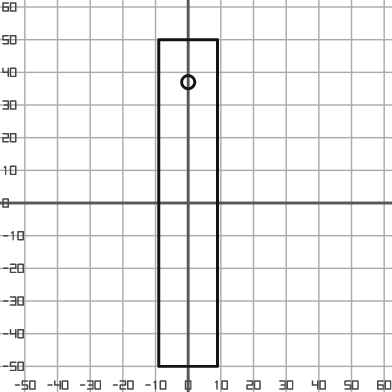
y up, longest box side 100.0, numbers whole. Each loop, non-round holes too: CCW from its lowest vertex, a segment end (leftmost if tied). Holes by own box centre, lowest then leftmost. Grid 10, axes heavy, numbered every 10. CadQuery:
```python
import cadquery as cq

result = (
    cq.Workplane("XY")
    .moveTo(-9.0, -50.0)
    .lineTo(9.0, -50.0)
    .lineTo(9.0, 50.0)
    .lineTo(-9.0, 50.0)
    .close()
    .moveTo(0.0, 37.0)
    .circle(2.0)
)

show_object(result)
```